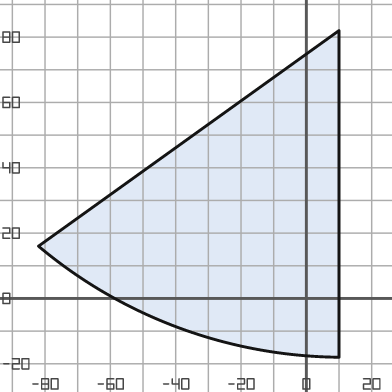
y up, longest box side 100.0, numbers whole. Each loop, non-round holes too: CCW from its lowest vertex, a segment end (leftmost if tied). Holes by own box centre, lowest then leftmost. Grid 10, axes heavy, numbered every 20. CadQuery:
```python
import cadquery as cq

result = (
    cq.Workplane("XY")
    .moveTo(10.0, -18.0)
    .lineTo(10.0, 82.0)
    .lineTo(-82.0, 16.0)
    .threePointArc((-39.0, -9.0), (10.0, -18.0))
    .close()
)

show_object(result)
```